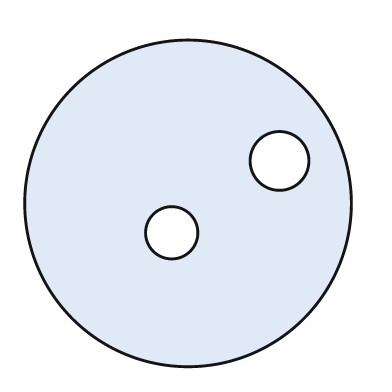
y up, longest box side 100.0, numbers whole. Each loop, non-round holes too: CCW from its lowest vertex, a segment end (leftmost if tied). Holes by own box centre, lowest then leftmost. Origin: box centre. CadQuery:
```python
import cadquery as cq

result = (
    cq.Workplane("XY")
    .moveTo(0.0, 0.0)
    .circle(50.0)
    .moveTo(-5.0, -9.0)
    .circle(8.0)
    .moveTo(28.0, 13.0)
    .circle(9.0)
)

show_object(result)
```